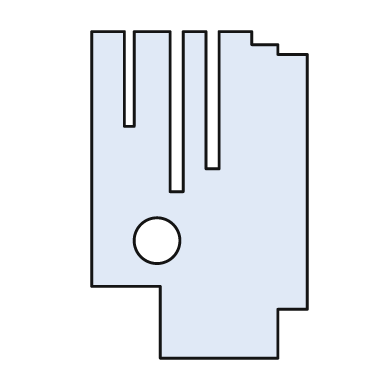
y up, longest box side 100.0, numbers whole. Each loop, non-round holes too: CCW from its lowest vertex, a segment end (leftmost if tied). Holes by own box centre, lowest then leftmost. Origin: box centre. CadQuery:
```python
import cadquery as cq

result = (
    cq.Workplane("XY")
    .moveTo(-12.0, -50.0)
    .lineTo(24.0, -50.0)
    .lineTo(24.0, -35.0)
    .lineTo(33.0, -35.0)
    .lineTo(33.0, 43.0)
    .lineTo(24.0, 43.0)
    .lineTo(24.0, 46.0)
    .lineTo(16.0, 46.0)
    .lineTo(16.0, 50.0)
    .lineTo(6.0, 50.0)
    .lineTo(6.0, 8.0)
    .lineTo(2.0, 8.0)
    .lineTo(2.0, 50.0)
    .lineTo(-5.0, 50.0)
    .lineTo(-5.0, 1.0)
    .lineTo(-9.0, 1.0)
    .lineTo(-9.0, 50.0)
    .lineTo(-20.0, 50.0)
    .lineTo(-20.0, 21.0)
    .lineTo(-23.0, 21.0)
    .lineTo(-23.0, 50.0)
    .lineTo(-33.0, 50.0)
    .lineTo(-33.0, -28.0)
    .lineTo(-12.0, -28.0)
    .close()
    .moveTo(-13.0, -14.0)
    .circle(7.0)
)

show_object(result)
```